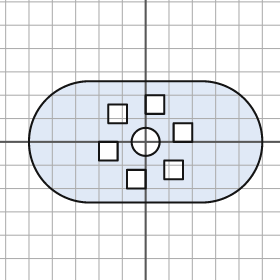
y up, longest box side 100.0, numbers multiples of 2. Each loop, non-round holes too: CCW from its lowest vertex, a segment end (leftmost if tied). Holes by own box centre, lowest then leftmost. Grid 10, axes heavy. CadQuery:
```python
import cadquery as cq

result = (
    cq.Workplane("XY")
    .moveTo(-24.0, -26.0)
    .lineTo(24.0, -26.0)
    .threePointArc((50.0, 0.0), (24.0, 26.0))
    .lineTo(-24.0, 26.0)
    .threePointArc((-50.0, 0.0), (-24.0, -26.0))
    .close()
    .moveTo(-8.0, -20.0)
    .lineTo(0.0, -20.0)
    .lineTo(0.0, -12.0)
    .lineTo(-8.0, -12.0)
    .close()
    .moveTo(8.0, -16.0)
    .lineTo(16.0, -16.0)
    .lineTo(16.0, -8.0)
    .lineTo(8.0, -8.0)
    .close()
    .moveTo(-20.0, -8.0)
    .lineTo(-12.0, -8.0)
    .lineTo(-12.0, 0.0)
    .lineTo(-20.0, 0.0)
    .close()
    .moveTo(0.0, 0.0)
    .circle(6.0)
    .moveTo(12.0, 0.0)
    .lineTo(20.0, 0.0)
    .lineTo(20.0, 8.0)
    .lineTo(12.0, 8.0)
    .close()
    .moveTo(-16.0, 8.0)
    .lineTo(-8.0, 8.0)
    .lineTo(-8.0, 16.0)
    .lineTo(-16.0, 16.0)
    .close()
    .moveTo(0.0, 12.0)
    .lineTo(8.0, 12.0)
    .lineTo(8.0, 20.0)
    .lineTo(0.0, 20.0)
    .close()
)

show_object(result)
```